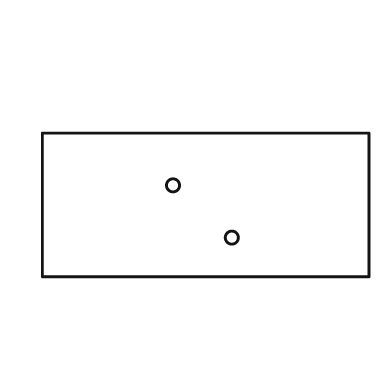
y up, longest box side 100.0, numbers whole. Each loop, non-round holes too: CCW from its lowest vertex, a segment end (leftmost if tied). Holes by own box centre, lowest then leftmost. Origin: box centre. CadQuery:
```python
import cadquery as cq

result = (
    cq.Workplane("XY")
    .moveTo(-50.0, -22.0)
    .lineTo(50.0, -22.0)
    .lineTo(50.0, 22.0)
    .lineTo(-50.0, 22.0)
    .close()
    .moveTo(8.0, -10.0)
    .circle(2.0)
    .moveTo(-10.0, 6.0)
    .circle(2.0)
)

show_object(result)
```